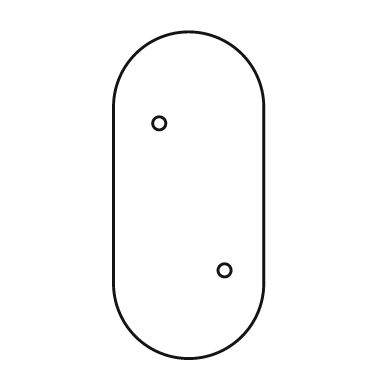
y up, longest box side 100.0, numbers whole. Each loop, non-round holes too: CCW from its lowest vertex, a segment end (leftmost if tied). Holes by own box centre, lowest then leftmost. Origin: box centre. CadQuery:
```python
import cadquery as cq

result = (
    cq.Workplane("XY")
    .moveTo(-23.0, -27.0)
    .threePointArc((0.0, -50.0), (23.0, -27.0))
    .lineTo(23.0, 27.0)
    .threePointArc((0.0, 50.0), (-23.0, 27.0))
    .close()
    .moveTo(11.0, -23.0)
    .circle(2.0)
    .moveTo(-9.0, 22.0)
    .circle(2.0)
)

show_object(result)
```